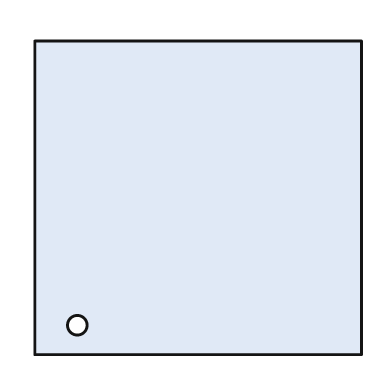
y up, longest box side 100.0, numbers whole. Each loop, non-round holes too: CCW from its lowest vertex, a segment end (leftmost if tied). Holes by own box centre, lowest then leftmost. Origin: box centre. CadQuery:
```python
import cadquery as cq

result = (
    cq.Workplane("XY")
    .moveTo(-50.0, -48.0)
    .lineTo(50.0, -48.0)
    .lineTo(50.0, 48.0)
    .lineTo(-50.0, 48.0)
    .close()
    .moveTo(-37.0, -39.0)
    .circle(3.0)
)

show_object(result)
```